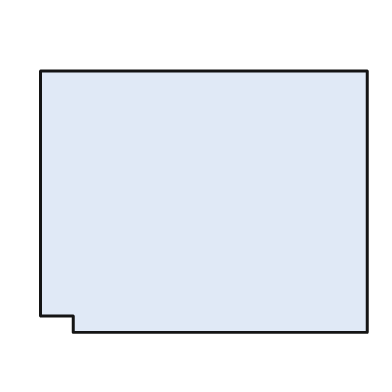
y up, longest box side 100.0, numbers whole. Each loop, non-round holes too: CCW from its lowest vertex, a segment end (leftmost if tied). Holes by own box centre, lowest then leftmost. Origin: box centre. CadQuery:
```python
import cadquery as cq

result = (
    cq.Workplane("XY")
    .moveTo(-40.0, -40.0)
    .lineTo(50.0, -40.0)
    .lineTo(50.0, 40.0)
    .lineTo(-50.0, 40.0)
    .lineTo(-50.0, -35.0)
    .lineTo(-40.0, -35.0)
    .close()
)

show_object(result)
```